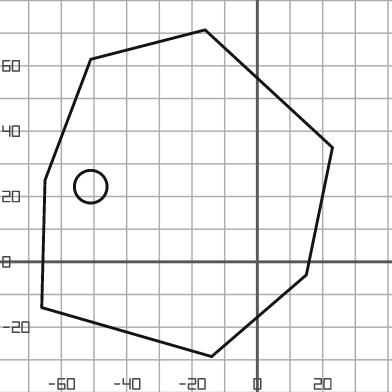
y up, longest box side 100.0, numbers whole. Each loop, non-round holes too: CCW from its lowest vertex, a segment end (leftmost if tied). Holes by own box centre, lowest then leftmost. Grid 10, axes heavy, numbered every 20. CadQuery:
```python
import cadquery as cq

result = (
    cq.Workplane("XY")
    .moveTo(-14.0, -29.0)
    .lineTo(15.0, -4.0)
    .lineTo(23.0, 35.0)
    .lineTo(-16.0, 71.0)
    .lineTo(-51.0, 62.0)
    .lineTo(-65.0, 25.0)
    .lineTo(-66.0, -14.0)
    .close()
    .moveTo(-51.0, 23.0)
    .circle(5.0)
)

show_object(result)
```